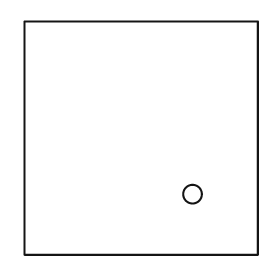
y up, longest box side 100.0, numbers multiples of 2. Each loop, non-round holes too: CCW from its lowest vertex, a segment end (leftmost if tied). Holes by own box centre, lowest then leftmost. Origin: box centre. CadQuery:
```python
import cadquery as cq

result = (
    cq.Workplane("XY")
    .moveTo(-50.0, -50.0)
    .lineTo(50.0, -50.0)
    .lineTo(50.0, 50.0)
    .lineTo(-50.0, 50.0)
    .close()
    .moveTo(22.0, -24.0)
    .circle(4.0)
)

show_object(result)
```